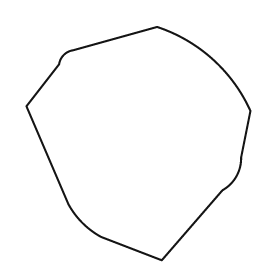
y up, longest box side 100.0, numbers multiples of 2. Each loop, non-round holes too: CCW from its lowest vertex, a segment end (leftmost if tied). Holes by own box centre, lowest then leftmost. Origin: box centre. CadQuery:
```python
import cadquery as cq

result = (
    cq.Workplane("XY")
    .moveTo(10.0, -50.0)
    .lineTo(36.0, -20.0)
    .threePointArc((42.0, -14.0), (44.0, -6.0))
    .lineTo(48.0, 14.0)
    .threePointArc((32.0, 36.0), (8.0, 50.0))
    .lineTo(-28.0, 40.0)
    .threePointArc((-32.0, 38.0), (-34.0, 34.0))
    .lineTo(-48.0, 16.0)
    .lineTo(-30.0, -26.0)
    .threePointArc((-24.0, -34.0), (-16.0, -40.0))
    .close()
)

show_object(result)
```